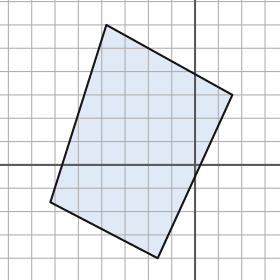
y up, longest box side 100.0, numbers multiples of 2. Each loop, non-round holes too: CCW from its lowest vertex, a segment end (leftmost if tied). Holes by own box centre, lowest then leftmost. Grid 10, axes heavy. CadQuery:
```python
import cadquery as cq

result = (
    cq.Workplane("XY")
    .moveTo(-16.0, -40.0)
    .lineTo(16.0, 30.0)
    .lineTo(-38.0, 60.0)
    .lineTo(-62.0, -16.0)
    .close()
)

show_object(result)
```